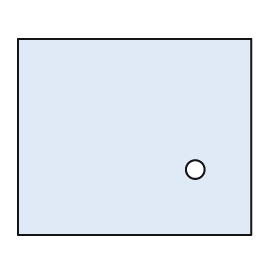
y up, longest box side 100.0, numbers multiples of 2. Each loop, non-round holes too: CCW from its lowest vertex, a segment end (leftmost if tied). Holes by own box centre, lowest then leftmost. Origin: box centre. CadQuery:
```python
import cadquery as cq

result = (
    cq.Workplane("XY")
    .moveTo(-50.0, -42.0)
    .lineTo(50.0, -42.0)
    .lineTo(50.0, 42.0)
    .lineTo(-50.0, 42.0)
    .close()
    .moveTo(26.0, -14.0)
    .circle(4.0)
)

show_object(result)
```